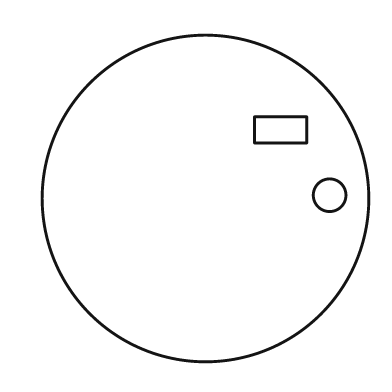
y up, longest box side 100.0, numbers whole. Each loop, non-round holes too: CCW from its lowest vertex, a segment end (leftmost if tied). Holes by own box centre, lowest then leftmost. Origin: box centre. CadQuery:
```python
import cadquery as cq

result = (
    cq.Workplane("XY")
    .moveTo(0.0, 0.0)
    .circle(50.0)
    .moveTo(38.0, 1.0)
    .circle(5.0)
    .moveTo(15.0, 17.0)
    .lineTo(31.0, 17.0)
    .lineTo(31.0, 25.0)
    .lineTo(15.0, 25.0)
    .close()
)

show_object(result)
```